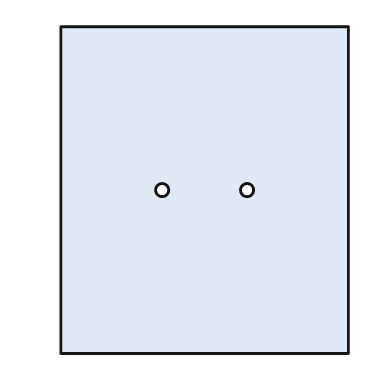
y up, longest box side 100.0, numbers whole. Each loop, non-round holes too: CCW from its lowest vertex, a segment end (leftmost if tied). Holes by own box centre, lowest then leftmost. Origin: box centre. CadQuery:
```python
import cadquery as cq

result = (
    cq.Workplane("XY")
    .moveTo(-44.0, -50.0)
    .lineTo(44.0, -50.0)
    .lineTo(44.0, 50.0)
    .lineTo(-44.0, 50.0)
    .close()
    .moveTo(-13.0, 0.0)
    .circle(2.0)
    .moveTo(13.0, 0.0)
    .circle(2.0)
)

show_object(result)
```